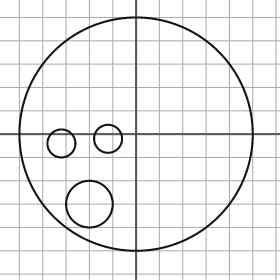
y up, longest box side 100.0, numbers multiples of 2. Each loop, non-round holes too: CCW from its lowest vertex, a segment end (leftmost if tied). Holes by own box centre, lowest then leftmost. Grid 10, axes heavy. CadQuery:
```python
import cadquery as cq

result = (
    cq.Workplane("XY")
    .moveTo(0.0, 0.0)
    .circle(50.0)
    .moveTo(-20.0, -30.0)
    .circle(10.0)
    .moveTo(-32.0, -4.0)
    .circle(6.0)
    .moveTo(-12.0, -2.0)
    .circle(6.0)
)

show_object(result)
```